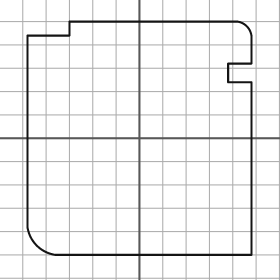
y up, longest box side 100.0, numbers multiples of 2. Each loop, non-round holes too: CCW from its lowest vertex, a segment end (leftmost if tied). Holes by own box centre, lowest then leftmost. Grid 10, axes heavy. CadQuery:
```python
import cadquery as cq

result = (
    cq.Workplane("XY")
    .moveTo(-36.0, -50.0)
    .lineTo(48.0, -50.0)
    .lineTo(48.0, 24.0)
    .lineTo(38.0, 24.0)
    .lineTo(38.0, 32.0)
    .lineTo(48.0, 32.0)
    .lineTo(48.0, 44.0)
    .threePointArc((46.0, 48.0), (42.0, 50.0))
    .lineTo(-30.0, 50.0)
    .lineTo(-30.0, 44.0)
    .lineTo(-48.0, 44.0)
    .lineTo(-48.0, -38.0)
    .threePointArc((-44.0, -46.0), (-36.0, -50.0))
    .close()
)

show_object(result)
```